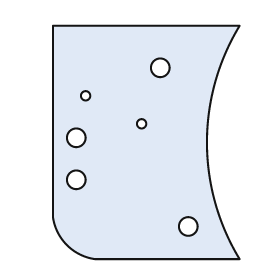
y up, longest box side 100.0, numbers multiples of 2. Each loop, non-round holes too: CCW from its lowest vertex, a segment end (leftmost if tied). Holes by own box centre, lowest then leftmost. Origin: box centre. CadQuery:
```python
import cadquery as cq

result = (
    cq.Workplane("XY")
    .moveTo(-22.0, -50.0)
    .lineTo(40.0, -50.0)
    .threePointArc((26.0, 0.0), (40.0, 50.0))
    .lineTo(-40.0, 50.0)
    .lineTo(-40.0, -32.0)
    .threePointArc((-34.0, -44.0), (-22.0, -50.0))
    .close()
    .moveTo(18.0, -36.0)
    .circle(4.0)
    .moveTo(-30.0, -16.0)
    .circle(4.0)
    .moveTo(-30.0, 2.0)
    .circle(4.0)
    .moveTo(-2.0, 8.0)
    .circle(2.0)
    .moveTo(-26.0, 20.0)
    .circle(2.0)
    .moveTo(6.0, 32.0)
    .circle(4.0)
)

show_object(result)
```